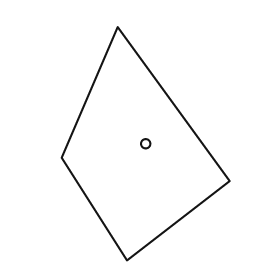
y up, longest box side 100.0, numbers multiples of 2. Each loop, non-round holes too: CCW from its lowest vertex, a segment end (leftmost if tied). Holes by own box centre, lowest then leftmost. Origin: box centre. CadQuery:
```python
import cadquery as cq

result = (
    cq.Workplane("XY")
    .moveTo(-8.0, -50.0)
    .lineTo(36.0, -16.0)
    .lineTo(-12.0, 50.0)
    .lineTo(-36.0, -6.0)
    .close()
    .moveTo(0.0, 0.0)
    .circle(2.0)
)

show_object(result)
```